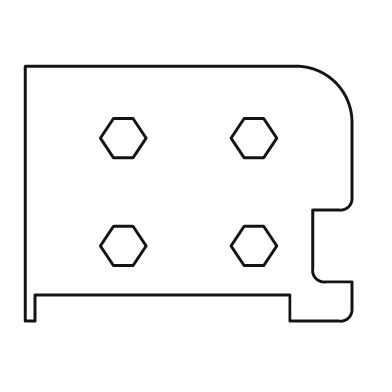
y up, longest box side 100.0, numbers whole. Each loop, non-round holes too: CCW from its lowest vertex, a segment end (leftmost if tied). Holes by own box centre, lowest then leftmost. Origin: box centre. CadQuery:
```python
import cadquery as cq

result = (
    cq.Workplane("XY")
    .moveTo(-50.0, -39.0)
    .lineTo(-47.0, -39.0)
    .lineTo(-47.0, -31.0)
    .lineTo(31.0, -31.0)
    .lineTo(31.0, -39.0)
    .lineTo(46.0, -39.0)
    .threePointArc((49.0, -38.0), (50.0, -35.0))
    .lineTo(50.0, -27.0)
    .lineTo(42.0, -27.0)
    .threePointArc((39.0, -26.0), (38.0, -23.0))
    .lineTo(38.0, -5.0)
    .lineTo(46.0, -5.0)
    .threePointArc((49.0, -4.0), (50.0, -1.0))
    .lineTo(50.0, 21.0)
    .threePointArc((45.0, 34.0), (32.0, 39.0))
    .lineTo(-50.0, 39.0)
    .close()
    .moveTo(-23.0, -22.0)
    .lineTo(-17.0, -22.0)
    .lineTo(-13.0, -16.0)
    .lineTo(-17.0, -10.0)
    .lineTo(-23.0, -10.0)
    .lineTo(-27.0, -16.0)
    .close()
    .moveTo(17.0, -22.0)
    .lineTo(23.0, -22.0)
    .lineTo(27.0, -16.0)
    .lineTo(23.0, -10.0)
    .lineTo(17.0, -10.0)
    .lineTo(13.0, -16.0)
    .close()
    .moveTo(-23.0, 11.0)
    .lineTo(-17.0, 11.0)
    .lineTo(-13.0, 17.0)
    .lineTo(-17.0, 23.0)
    .lineTo(-23.0, 23.0)
    .lineTo(-27.0, 17.0)
    .close()
    .moveTo(17.0, 11.0)
    .lineTo(23.0, 11.0)
    .lineTo(27.0, 17.0)
    .lineTo(23.0, 23.0)
    .lineTo(17.0, 23.0)
    .lineTo(13.0, 17.0)
    .close()
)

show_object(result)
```